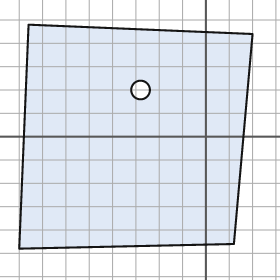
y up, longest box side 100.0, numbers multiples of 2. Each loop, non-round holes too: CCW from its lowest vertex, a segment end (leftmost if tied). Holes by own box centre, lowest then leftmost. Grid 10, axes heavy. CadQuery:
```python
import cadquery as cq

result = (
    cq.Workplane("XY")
    .moveTo(-80.0, -48.0)
    .lineTo(12.0, -46.0)
    .lineTo(20.0, 44.0)
    .lineTo(-76.0, 48.0)
    .close()
    .moveTo(-28.0, 20.0)
    .circle(4.0)
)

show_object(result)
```